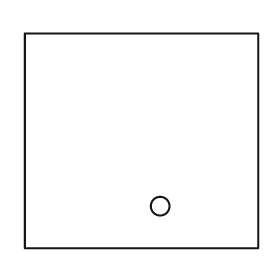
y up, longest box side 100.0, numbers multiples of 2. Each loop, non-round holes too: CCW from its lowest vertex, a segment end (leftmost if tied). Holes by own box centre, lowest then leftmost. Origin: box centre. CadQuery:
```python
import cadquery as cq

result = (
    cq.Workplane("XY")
    .moveTo(-50.0, -46.0)
    .lineTo(50.0, -46.0)
    .lineTo(50.0, 46.0)
    .lineTo(-50.0, 46.0)
    .close()
    .moveTo(8.0, -28.0)
    .circle(4.0)
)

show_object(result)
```